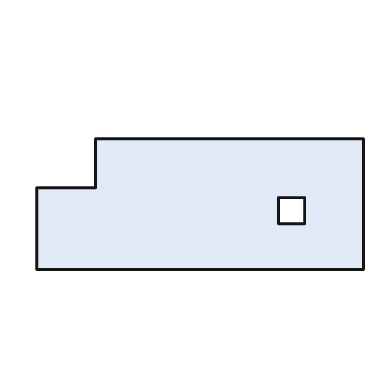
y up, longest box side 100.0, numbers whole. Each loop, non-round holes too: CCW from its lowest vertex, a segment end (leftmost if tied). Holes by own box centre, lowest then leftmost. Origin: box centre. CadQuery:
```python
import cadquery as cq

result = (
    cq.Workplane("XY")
    .moveTo(-50.0, -20.0)
    .lineTo(50.0, -20.0)
    .lineTo(50.0, 20.0)
    .lineTo(-32.0, 20.0)
    .lineTo(-32.0, 5.0)
    .lineTo(-50.0, 5.0)
    .close()
    .moveTo(24.0, -6.0)
    .lineTo(32.0, -6.0)
    .lineTo(32.0, 2.0)
    .lineTo(24.0, 2.0)
    .close()
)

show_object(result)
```